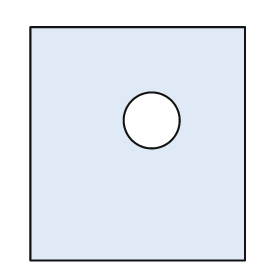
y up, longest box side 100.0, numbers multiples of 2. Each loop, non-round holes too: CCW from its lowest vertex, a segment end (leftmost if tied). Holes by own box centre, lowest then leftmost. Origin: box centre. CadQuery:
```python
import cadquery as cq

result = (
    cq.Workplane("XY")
    .moveTo(-46.0, -50.0)
    .lineTo(46.0, -50.0)
    .lineTo(46.0, 50.0)
    .lineTo(-46.0, 50.0)
    .close()
    .moveTo(6.0, 10.0)
    .circle(12.0)
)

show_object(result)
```